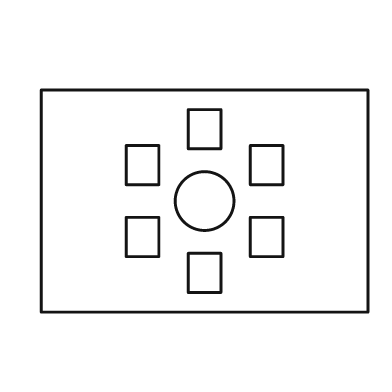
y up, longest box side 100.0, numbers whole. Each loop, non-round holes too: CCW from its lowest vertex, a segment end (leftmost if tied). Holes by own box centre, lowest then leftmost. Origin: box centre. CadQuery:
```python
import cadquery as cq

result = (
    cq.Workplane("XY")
    .moveTo(-50.0, -34.0)
    .lineTo(50.0, -34.0)
    .lineTo(50.0, 34.0)
    .lineTo(-50.0, 34.0)
    .close()
    .moveTo(-5.0, -28.0)
    .lineTo(5.0, -28.0)
    .lineTo(5.0, -16.0)
    .lineTo(-5.0, -16.0)
    .close()
    .moveTo(-24.0, -17.0)
    .lineTo(-14.0, -17.0)
    .lineTo(-14.0, -5.0)
    .lineTo(-24.0, -5.0)
    .close()
    .moveTo(14.0, -17.0)
    .lineTo(24.0, -17.0)
    .lineTo(24.0, -5.0)
    .lineTo(14.0, -5.0)
    .close()
    .moveTo(0.0, 0.0)
    .circle(9.0)
    .moveTo(-24.0, 5.0)
    .lineTo(-14.0, 5.0)
    .lineTo(-14.0, 17.0)
    .lineTo(-24.0, 17.0)
    .close()
    .moveTo(14.0, 5.0)
    .lineTo(24.0, 5.0)
    .lineTo(24.0, 17.0)
    .lineTo(14.0, 17.0)
    .close()
    .moveTo(-5.0, 16.0)
    .lineTo(5.0, 16.0)
    .lineTo(5.0, 28.0)
    .lineTo(-5.0, 28.0)
    .close()
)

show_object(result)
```